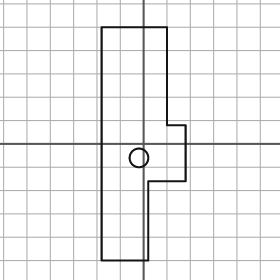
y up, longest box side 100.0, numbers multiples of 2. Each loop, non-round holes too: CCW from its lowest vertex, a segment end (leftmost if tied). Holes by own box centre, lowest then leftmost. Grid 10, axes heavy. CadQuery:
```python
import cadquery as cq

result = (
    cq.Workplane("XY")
    .moveTo(-18.0, -50.0)
    .lineTo(2.0, -50.0)
    .lineTo(2.0, -16.0)
    .lineTo(18.0, -16.0)
    .lineTo(18.0, 8.0)
    .lineTo(10.0, 8.0)
    .lineTo(10.0, 50.0)
    .lineTo(-18.0, 50.0)
    .close()
    .moveTo(-2.0, -6.0)
    .circle(4.0)
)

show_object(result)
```